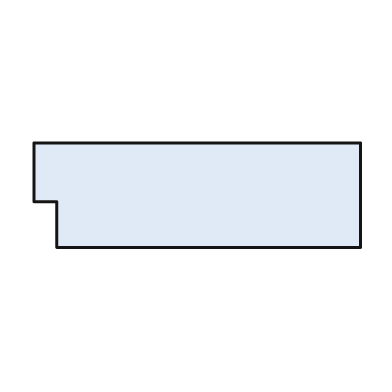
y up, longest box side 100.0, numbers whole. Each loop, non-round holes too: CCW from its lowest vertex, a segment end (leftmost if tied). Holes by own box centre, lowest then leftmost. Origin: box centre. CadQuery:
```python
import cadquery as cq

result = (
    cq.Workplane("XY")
    .moveTo(-43.0, -16.0)
    .lineTo(50.0, -16.0)
    .lineTo(50.0, 16.0)
    .lineTo(-50.0, 16.0)
    .lineTo(-50.0, -2.0)
    .lineTo(-43.0, -2.0)
    .close()
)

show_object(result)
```